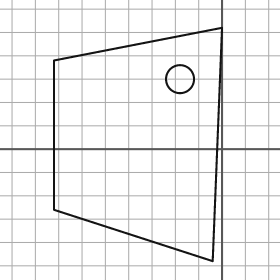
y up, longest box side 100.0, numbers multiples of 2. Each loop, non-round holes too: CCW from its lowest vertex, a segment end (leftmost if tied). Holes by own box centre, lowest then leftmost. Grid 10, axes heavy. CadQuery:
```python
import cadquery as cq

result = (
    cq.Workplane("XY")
    .moveTo(-4.0, -48.0)
    .lineTo(0.0, 52.0)
    .lineTo(-72.0, 38.0)
    .lineTo(-72.0, -26.0)
    .close()
    .moveTo(-18.0, 30.0)
    .circle(6.0)
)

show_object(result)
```